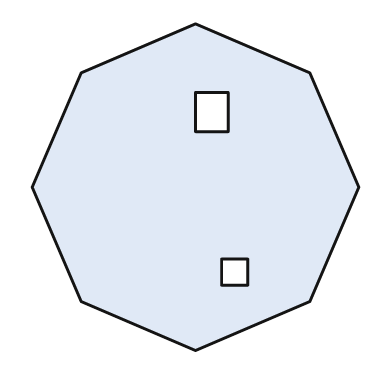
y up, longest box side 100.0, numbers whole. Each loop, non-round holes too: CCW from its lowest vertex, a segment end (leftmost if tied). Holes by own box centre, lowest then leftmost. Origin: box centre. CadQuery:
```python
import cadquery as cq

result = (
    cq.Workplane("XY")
    .moveTo(0.0, -50.0)
    .lineTo(35.0, -35.0)
    .lineTo(50.0, 0.0)
    .lineTo(35.0, 35.0)
    .lineTo(0.0, 50.0)
    .lineTo(-35.0, 35.0)
    .lineTo(-50.0, 0.0)
    .lineTo(-35.0, -35.0)
    .close()
    .moveTo(8.0, -30.0)
    .lineTo(16.0, -30.0)
    .lineTo(16.0, -22.0)
    .lineTo(8.0, -22.0)
    .close()
    .moveTo(0.0, 17.0)
    .lineTo(10.0, 17.0)
    .lineTo(10.0, 29.0)
    .lineTo(0.0, 29.0)
    .close()
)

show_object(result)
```